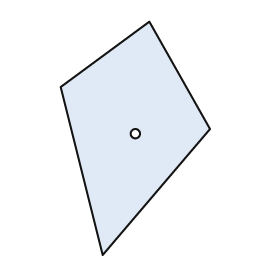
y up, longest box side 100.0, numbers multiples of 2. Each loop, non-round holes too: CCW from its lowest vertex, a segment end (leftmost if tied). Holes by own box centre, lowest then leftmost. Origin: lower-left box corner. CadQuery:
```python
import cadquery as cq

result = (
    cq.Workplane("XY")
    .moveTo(18.0, 0.0)
    .lineTo(64.0, 54.0)
    .lineTo(38.0, 100.0)
    .lineTo(0.0, 72.0)
    .close()
    .moveTo(32.0, 52.0)
    .circle(2.0)
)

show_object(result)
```